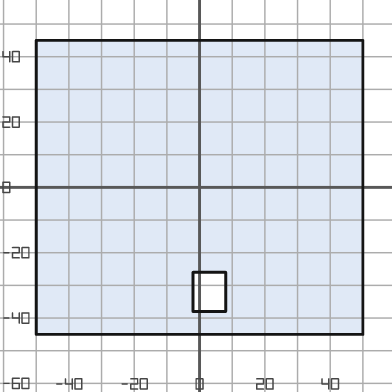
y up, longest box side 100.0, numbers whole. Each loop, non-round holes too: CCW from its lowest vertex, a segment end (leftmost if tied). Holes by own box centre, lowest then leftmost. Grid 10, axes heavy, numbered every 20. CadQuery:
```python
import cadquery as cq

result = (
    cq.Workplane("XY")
    .moveTo(-50.0, -45.0)
    .lineTo(50.0, -45.0)
    .lineTo(50.0, 45.0)
    .lineTo(-50.0, 45.0)
    .close()
    .moveTo(-2.0, -38.0)
    .lineTo(8.0, -38.0)
    .lineTo(8.0, -26.0)
    .lineTo(-2.0, -26.0)
    .close()
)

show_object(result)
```